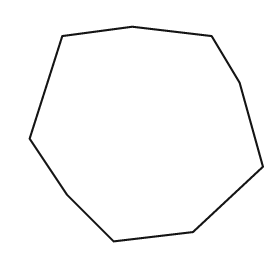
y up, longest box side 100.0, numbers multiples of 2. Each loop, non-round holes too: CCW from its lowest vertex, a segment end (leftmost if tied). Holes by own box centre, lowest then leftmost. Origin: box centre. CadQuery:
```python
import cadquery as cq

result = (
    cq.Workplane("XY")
    .moveTo(-14.0, -46.0)
    .lineTo(20.0, -42.0)
    .lineTo(50.0, -14.0)
    .lineTo(40.0, 22.0)
    .lineTo(28.0, 42.0)
    .lineTo(-6.0, 46.0)
    .lineTo(-36.0, 42.0)
    .lineTo(-50.0, -2.0)
    .lineTo(-34.0, -26.0)
    .close()
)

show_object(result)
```